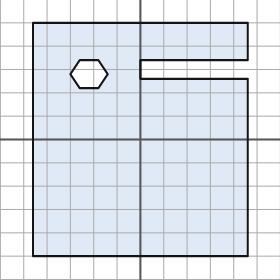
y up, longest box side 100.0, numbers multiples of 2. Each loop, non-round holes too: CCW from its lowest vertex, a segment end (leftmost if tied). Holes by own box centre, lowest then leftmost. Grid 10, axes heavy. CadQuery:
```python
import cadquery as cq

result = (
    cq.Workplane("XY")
    .moveTo(-46.0, -50.0)
    .lineTo(46.0, -50.0)
    .lineTo(46.0, 26.0)
    .lineTo(0.0, 26.0)
    .lineTo(0.0, 34.0)
    .lineTo(46.0, 34.0)
    .lineTo(46.0, 50.0)
    .lineTo(-46.0, 50.0)
    .close()
    .moveTo(-26.0, 22.0)
    .lineTo(-18.0, 22.0)
    .lineTo(-14.0, 28.0)
    .lineTo(-18.0, 34.0)
    .lineTo(-26.0, 34.0)
    .lineTo(-30.0, 28.0)
    .close()
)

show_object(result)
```